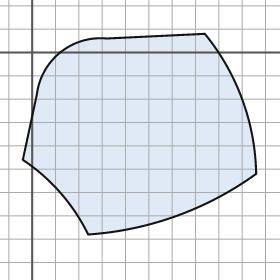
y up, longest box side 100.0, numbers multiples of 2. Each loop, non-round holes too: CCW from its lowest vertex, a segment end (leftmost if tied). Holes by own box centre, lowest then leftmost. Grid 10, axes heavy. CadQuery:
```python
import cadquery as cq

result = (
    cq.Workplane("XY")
    .moveTo(24.0, -78.0)
    .threePointArc((62.0, -70.0), (96.0, -52.0))
    .threePointArc((90.0, -20.0), (74.0, 8.0))
    .lineTo(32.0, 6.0)
    .threePointArc((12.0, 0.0), (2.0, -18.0))
    .lineTo(-4.0, -46.0)
    .threePointArc((12.0, -60.0), (24.0, -78.0))
    .close()
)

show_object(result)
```